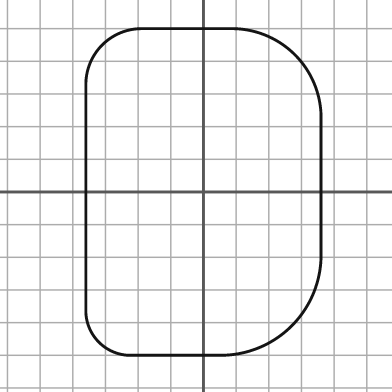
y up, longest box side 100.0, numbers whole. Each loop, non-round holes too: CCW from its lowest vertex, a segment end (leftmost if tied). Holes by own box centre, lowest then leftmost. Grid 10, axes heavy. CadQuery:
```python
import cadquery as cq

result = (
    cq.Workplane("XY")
    .moveTo(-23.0, -50.0)
    .lineTo(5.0, -50.0)
    .threePointArc((27.0, -41.0), (36.0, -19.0))
    .lineTo(36.0, 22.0)
    .threePointArc((28.0, 42.0), (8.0, 50.0))
    .lineTo(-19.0, 50.0)
    .threePointArc((-31.0, 45.0), (-36.0, 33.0))
    .lineTo(-36.0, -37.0)
    .threePointArc((-32.0, -46.0), (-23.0, -50.0))
    .close()
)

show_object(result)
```